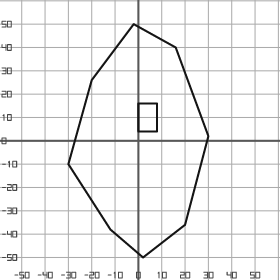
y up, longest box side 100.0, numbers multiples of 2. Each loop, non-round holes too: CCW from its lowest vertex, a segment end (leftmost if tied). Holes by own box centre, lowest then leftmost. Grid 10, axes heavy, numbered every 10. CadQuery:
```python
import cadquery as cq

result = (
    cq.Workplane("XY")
    .moveTo(2.0, -50.0)
    .lineTo(20.0, -36.0)
    .lineTo(30.0, 2.0)
    .lineTo(16.0, 40.0)
    .lineTo(-2.0, 50.0)
    .lineTo(-20.0, 26.0)
    .lineTo(-30.0, -10.0)
    .lineTo(-12.0, -38.0)
    .close()
    .moveTo(0.0, 4.0)
    .lineTo(8.0, 4.0)
    .lineTo(8.0, 16.0)
    .lineTo(0.0, 16.0)
    .close()
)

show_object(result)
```